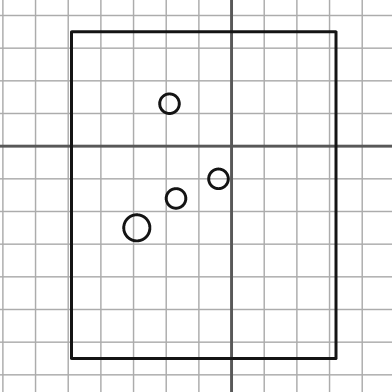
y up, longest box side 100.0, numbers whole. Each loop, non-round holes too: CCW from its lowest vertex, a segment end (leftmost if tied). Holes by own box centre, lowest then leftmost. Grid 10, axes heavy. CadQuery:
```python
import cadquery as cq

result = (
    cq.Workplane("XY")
    .moveTo(-49.0, -65.0)
    .lineTo(32.0, -65.0)
    .lineTo(32.0, 35.0)
    .lineTo(-49.0, 35.0)
    .close()
    .moveTo(-29.0, -25.0)
    .circle(4.0)
    .moveTo(-17.0, -16.0)
    .circle(3.0)
    .moveTo(-4.0, -10.0)
    .circle(3.0)
    .moveTo(-19.0, 13.0)
    .circle(3.0)
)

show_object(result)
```